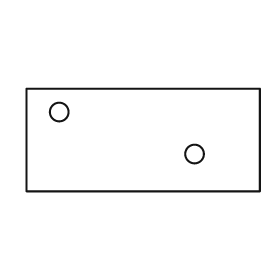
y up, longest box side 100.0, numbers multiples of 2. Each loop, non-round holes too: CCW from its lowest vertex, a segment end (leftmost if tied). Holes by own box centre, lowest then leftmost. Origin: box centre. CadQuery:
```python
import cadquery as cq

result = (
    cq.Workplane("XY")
    .moveTo(-50.0, -22.0)
    .lineTo(50.0, -22.0)
    .lineTo(50.0, 22.0)
    .lineTo(-50.0, 22.0)
    .close()
    .moveTo(22.0, -6.0)
    .circle(4.0)
    .moveTo(-36.0, 12.0)
    .circle(4.0)
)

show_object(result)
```